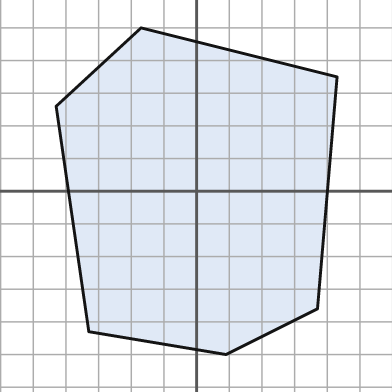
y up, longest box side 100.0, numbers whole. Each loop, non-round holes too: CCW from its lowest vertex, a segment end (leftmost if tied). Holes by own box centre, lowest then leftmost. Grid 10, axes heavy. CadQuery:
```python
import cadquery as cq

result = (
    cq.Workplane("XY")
    .moveTo(9.0, -50.0)
    .lineTo(37.0, -36.0)
    .lineTo(43.0, 35.0)
    .lineTo(-17.0, 50.0)
    .lineTo(-43.0, 26.0)
    .lineTo(-33.0, -43.0)
    .close()
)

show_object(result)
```